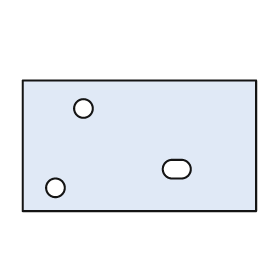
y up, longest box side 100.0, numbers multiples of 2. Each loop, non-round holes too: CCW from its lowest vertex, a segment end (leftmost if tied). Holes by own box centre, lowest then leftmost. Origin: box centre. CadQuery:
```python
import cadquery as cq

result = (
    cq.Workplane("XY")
    .moveTo(-50.0, -28.0)
    .lineTo(50.0, -28.0)
    .lineTo(50.0, 28.0)
    .lineTo(-50.0, 28.0)
    .close()
    .moveTo(-36.0, -18.0)
    .circle(4.0)
    .moveTo(14.0, -14.0)
    .lineTo(18.0, -14.0)
    .threePointArc((22.0, -10.0), (18.0, -6.0))
    .lineTo(14.0, -6.0)
    .threePointArc((10.0, -10.0), (14.0, -14.0))
    .close()
    .moveTo(-24.0, 16.0)
    .circle(4.0)
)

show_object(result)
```